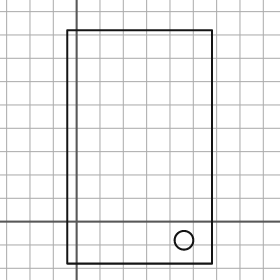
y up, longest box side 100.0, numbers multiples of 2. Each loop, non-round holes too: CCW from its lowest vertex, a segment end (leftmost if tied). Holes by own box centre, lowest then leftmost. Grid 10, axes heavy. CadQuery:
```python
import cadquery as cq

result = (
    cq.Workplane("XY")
    .moveTo(-4.0, -18.0)
    .lineTo(58.0, -18.0)
    .lineTo(58.0, 82.0)
    .lineTo(-4.0, 82.0)
    .close()
    .moveTo(46.0, -8.0)
    .circle(4.0)
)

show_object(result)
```